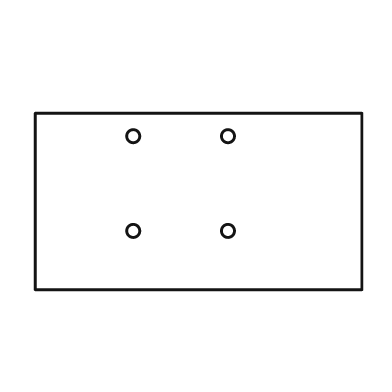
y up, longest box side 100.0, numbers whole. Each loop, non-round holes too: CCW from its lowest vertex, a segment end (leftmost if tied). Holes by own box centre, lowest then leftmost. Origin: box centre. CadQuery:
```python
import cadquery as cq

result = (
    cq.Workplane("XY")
    .moveTo(-50.0, -27.0)
    .lineTo(50.0, -27.0)
    .lineTo(50.0, 27.0)
    .lineTo(-50.0, 27.0)
    .close()
    .moveTo(-20.0, -9.0)
    .circle(2.0)
    .moveTo(9.0, -9.0)
    .circle(2.0)
    .moveTo(-20.0, 20.0)
    .circle(2.0)
    .moveTo(9.0, 20.0)
    .circle(2.0)
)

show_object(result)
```